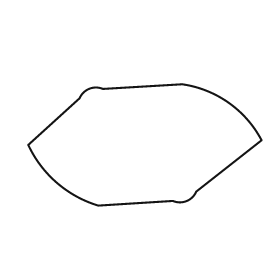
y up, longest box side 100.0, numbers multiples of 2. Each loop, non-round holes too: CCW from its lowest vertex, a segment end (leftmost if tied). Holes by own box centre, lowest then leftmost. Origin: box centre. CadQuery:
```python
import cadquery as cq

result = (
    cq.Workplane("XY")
    .moveTo(-20.0, -26.0)
    .lineTo(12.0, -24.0)
    .threePointArc((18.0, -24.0), (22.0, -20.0))
    .lineTo(50.0, 2.0)
    .threePointArc((36.0, 18.0), (16.0, 26.0))
    .lineTo(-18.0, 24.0)
    .threePointArc((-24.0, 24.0), (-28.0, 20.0))
    .lineTo(-50.0, 0.0)
    .threePointArc((-38.0, -16.0), (-20.0, -26.0))
    .close()
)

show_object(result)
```